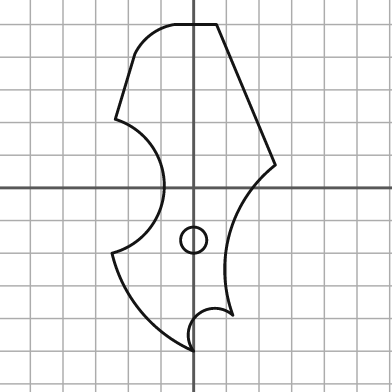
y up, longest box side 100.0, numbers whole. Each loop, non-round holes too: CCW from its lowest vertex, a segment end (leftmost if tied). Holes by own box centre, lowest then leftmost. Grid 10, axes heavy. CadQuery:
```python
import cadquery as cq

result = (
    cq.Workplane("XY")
    .moveTo(0.0, -50.0)
    .threePointArc((1.0, -39.0), (12.0, -39.0))
    .threePointArc((11.0, -14.0), (25.0, 7.0))
    .lineTo(7.0, 50.0)
    .lineTo(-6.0, 50.0)
    .threePointArc((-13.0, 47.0), (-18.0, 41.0))
    .lineTo(-24.0, 21.0)
    .threePointArc((-9.0, 0.0), (-25.0, -20.0))
    .threePointArc((-16.0, -38.0), (0.0, -50.0))
    .close()
    .moveTo(0.0, -16.0)
    .circle(4.0)
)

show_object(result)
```